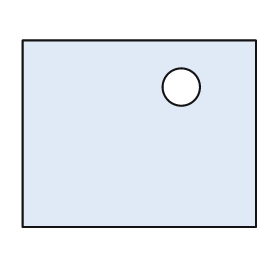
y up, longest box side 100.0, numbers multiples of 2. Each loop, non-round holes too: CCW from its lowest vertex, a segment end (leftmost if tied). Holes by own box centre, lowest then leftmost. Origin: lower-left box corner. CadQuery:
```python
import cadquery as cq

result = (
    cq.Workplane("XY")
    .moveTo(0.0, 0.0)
    .lineTo(100.0, 0.0)
    .lineTo(100.0, 80.0)
    .lineTo(0.0, 80.0)
    .close()
    .moveTo(68.0, 60.0)
    .circle(8.0)
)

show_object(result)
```